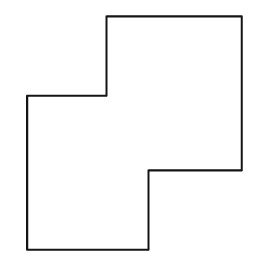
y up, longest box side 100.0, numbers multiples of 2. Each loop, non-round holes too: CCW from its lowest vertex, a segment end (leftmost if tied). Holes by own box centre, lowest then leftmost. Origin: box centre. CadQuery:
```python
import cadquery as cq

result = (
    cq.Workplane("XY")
    .moveTo(-46.0, -50.0)
    .lineTo(6.0, -50.0)
    .lineTo(6.0, -16.0)
    .lineTo(46.0, -16.0)
    .lineTo(46.0, 50.0)
    .lineTo(-12.0, 50.0)
    .lineTo(-12.0, 16.0)
    .lineTo(-46.0, 16.0)
    .close()
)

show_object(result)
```